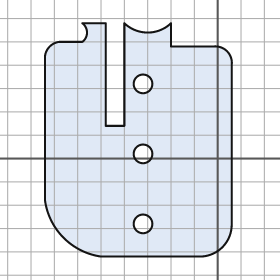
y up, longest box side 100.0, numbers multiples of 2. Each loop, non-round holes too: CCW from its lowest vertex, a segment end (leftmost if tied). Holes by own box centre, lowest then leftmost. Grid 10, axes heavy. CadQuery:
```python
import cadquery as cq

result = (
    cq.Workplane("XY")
    .moveTo(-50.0, -42.0)
    .lineTo(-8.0, -42.0)
    .threePointArc((2.0, -38.0), (6.0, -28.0))
    .lineTo(6.0, 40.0)
    .threePointArc((4.0, 46.0), (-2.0, 48.0))
    .lineTo(-20.0, 48.0)
    .lineTo(-20.0, 58.0)
    .threePointArc((-30.0, 54.0), (-40.0, 58.0))
    .lineTo(-40.0, 14.0)
    .lineTo(-48.0, 14.0)
    .lineTo(-48.0, 58.0)
    .lineTo(-58.0, 58.0)
    .threePointArc((-56.0, 54.0), (-58.0, 50.0))
    .lineTo(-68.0, 50.0)
    .threePointArc((-72.0, 48.0), (-74.0, 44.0))
    .lineTo(-74.0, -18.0)
    .threePointArc((-66.0, -34.0), (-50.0, -42.0))
    .close()
    .moveTo(-32.0, -28.0)
    .circle(4.0)
    .moveTo(-32.0, 2.0)
    .circle(4.0)
    .moveTo(-32.0, 32.0)
    .circle(4.0)
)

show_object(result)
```